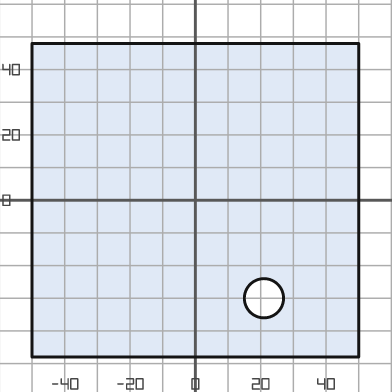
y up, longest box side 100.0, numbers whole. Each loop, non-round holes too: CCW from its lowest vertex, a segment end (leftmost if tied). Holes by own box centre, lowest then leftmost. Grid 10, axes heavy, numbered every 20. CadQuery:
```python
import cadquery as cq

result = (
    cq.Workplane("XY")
    .moveTo(-50.0, -48.0)
    .lineTo(50.0, -48.0)
    .lineTo(50.0, 48.0)
    .lineTo(-50.0, 48.0)
    .close()
    .moveTo(21.0, -30.0)
    .circle(6.0)
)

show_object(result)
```